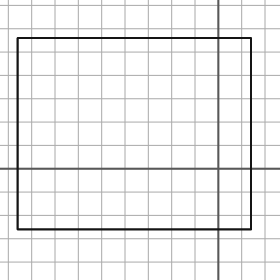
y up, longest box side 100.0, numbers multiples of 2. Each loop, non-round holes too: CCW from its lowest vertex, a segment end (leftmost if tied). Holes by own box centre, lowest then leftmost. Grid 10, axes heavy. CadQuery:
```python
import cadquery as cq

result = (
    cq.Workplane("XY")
    .moveTo(-86.0, -26.0)
    .lineTo(14.0, -26.0)
    .lineTo(14.0, 56.0)
    .lineTo(-86.0, 56.0)
    .close()
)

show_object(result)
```